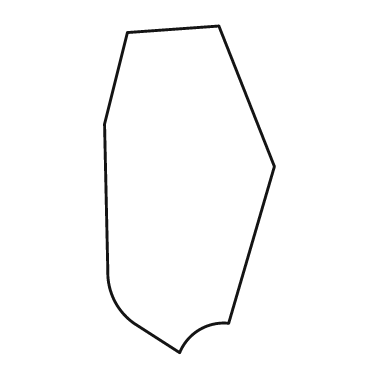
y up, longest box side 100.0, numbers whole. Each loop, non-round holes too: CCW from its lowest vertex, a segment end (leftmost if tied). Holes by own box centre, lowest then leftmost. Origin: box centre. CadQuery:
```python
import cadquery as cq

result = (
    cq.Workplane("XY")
    .moveTo(-3.0, -50.0)
    .threePointArc((3.0, -43.0), (12.0, -41.0))
    .lineTo(26.0, 7.0)
    .lineTo(9.0, 50.0)
    .lineTo(-19.0, 48.0)
    .lineTo(-26.0, 20.0)
    .lineTo(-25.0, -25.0)
    .threePointArc((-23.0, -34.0), (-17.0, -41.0))
    .close()
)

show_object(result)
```